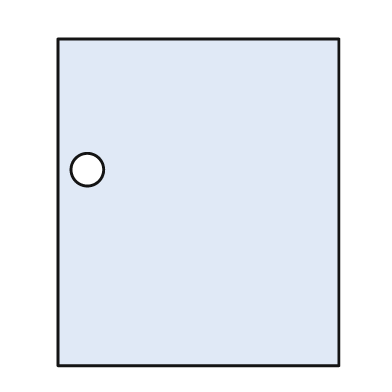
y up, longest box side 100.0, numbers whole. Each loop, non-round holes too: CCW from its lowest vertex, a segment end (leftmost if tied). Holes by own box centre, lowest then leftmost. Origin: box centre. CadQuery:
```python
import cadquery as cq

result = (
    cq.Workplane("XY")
    .moveTo(-43.0, -50.0)
    .lineTo(43.0, -50.0)
    .lineTo(43.0, 50.0)
    .lineTo(-43.0, 50.0)
    .close()
    .moveTo(-34.0, 10.0)
    .circle(5.0)
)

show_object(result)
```